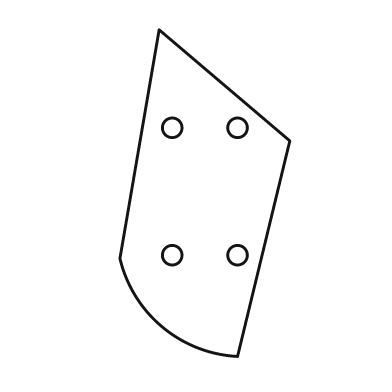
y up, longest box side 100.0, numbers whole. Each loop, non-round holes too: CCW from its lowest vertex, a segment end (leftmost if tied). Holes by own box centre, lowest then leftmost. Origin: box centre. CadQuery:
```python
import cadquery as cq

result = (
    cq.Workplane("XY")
    .moveTo(10.0, -50.0)
    .lineTo(26.0, 16.0)
    .lineTo(-14.0, 50.0)
    .lineTo(-26.0, -20.0)
    .threePointArc((-13.0, -41.0), (10.0, -50.0))
    .close()
    .moveTo(-10.0, -19.0)
    .circle(3.0)
    .moveTo(10.0, -19.0)
    .circle(3.0)
    .moveTo(-10.0, 20.0)
    .circle(3.0)
    .moveTo(10.0, 20.0)
    .circle(3.0)
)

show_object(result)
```